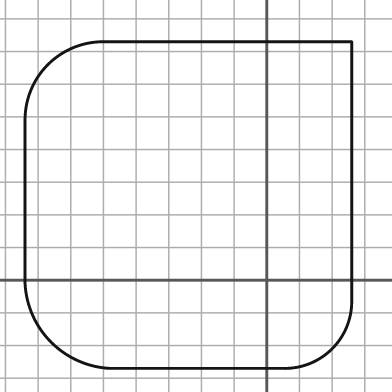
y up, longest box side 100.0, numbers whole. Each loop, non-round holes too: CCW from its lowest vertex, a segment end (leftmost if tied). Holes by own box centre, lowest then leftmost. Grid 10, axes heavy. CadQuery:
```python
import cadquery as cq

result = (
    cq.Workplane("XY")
    .moveTo(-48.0, -27.0)
    .lineTo(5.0, -27.0)
    .threePointArc((20.0, -21.0), (26.0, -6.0))
    .lineTo(26.0, 73.0)
    .lineTo(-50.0, 73.0)
    .threePointArc((-67.0, 66.0), (-74.0, 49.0))
    .lineTo(-74.0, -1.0)
    .threePointArc((-66.0, -19.0), (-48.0, -27.0))
    .close()
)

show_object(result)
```